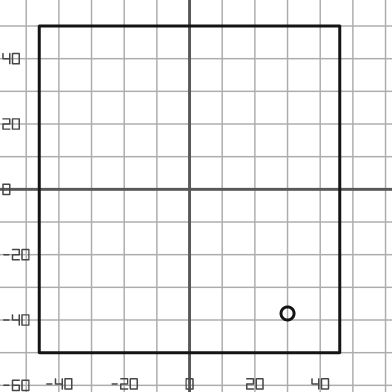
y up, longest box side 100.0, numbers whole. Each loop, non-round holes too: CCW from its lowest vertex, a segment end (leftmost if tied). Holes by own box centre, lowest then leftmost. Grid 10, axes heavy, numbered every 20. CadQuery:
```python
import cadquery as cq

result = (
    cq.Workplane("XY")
    .moveTo(-46.0, -50.0)
    .lineTo(46.0, -50.0)
    .lineTo(46.0, 50.0)
    .lineTo(-46.0, 50.0)
    .close()
    .moveTo(30.0, -38.0)
    .circle(2.0)
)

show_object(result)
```